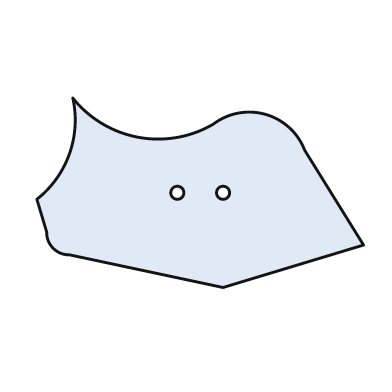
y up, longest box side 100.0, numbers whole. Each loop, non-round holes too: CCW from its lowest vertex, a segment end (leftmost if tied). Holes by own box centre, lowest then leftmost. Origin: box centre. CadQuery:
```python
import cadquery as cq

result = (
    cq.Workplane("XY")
    .moveTo(7.0, -29.0)
    .lineTo(50.0, -16.0)
    .lineTo(32.0, 13.0)
    .threePointArc((20.0, 24.0), (4.0, 21.0))
    .threePointArc((-19.0, 17.0), (-39.0, 29.0))
    .threePointArc((-40.0, 12.0), (-50.0, -2.0))
    .lineTo(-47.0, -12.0)
    .threePointArc((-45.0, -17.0), (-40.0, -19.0))
    .close()
    .moveTo(-7.0, 0.0)
    .circle(2.0)
    .moveTo(7.0, 0.0)
    .circle(2.0)
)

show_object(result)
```